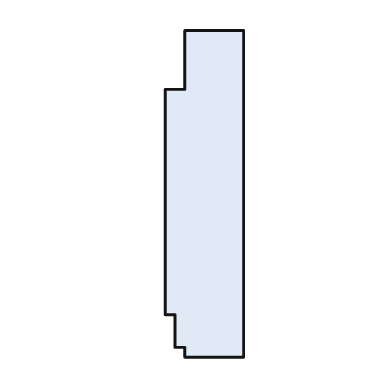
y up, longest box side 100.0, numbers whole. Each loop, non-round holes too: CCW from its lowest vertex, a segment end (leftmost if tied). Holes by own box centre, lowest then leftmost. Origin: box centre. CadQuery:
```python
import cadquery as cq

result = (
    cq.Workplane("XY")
    .moveTo(-6.0, -50.0)
    .lineTo(12.0, -50.0)
    .lineTo(12.0, 50.0)
    .lineTo(-6.0, 50.0)
    .lineTo(-6.0, 32.0)
    .lineTo(-12.0, 32.0)
    .lineTo(-12.0, -37.0)
    .lineTo(-9.0, -37.0)
    .lineTo(-9.0, -47.0)
    .lineTo(-6.0, -47.0)
    .close()
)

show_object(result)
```